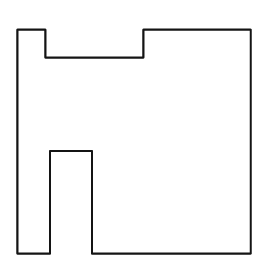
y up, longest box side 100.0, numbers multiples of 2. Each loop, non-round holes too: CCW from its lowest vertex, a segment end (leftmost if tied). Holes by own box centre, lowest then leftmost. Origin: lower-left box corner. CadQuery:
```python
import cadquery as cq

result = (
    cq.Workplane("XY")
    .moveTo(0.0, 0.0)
    .lineTo(14.0, 0.0)
    .lineTo(14.0, 44.0)
    .lineTo(32.0, 44.0)
    .lineTo(32.0, 0.0)
    .lineTo(100.0, 0.0)
    .lineTo(100.0, 96.0)
    .lineTo(54.0, 96.0)
    .lineTo(54.0, 84.0)
    .lineTo(12.0, 84.0)
    .lineTo(12.0, 96.0)
    .lineTo(0.0, 96.0)
    .close()
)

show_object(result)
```